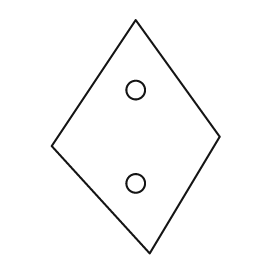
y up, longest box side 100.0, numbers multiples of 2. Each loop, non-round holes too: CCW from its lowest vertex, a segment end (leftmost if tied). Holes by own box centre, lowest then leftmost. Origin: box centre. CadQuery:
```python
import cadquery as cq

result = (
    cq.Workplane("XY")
    .moveTo(6.0, -50.0)
    .lineTo(36.0, 0.0)
    .lineTo(0.0, 50.0)
    .lineTo(-36.0, -4.0)
    .close()
    .moveTo(0.0, -20.0)
    .circle(4.0)
    .moveTo(0.0, 20.0)
    .circle(4.0)
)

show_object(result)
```